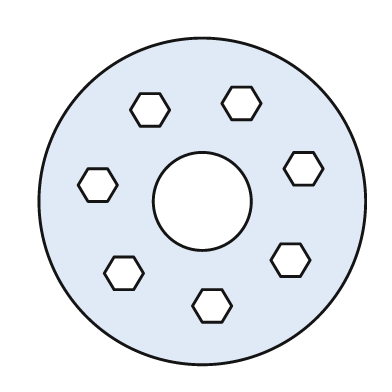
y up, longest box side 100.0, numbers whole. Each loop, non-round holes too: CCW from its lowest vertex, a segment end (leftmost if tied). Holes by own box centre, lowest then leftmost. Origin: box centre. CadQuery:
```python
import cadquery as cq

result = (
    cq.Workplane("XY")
    .moveTo(0.0, 0.0)
    .circle(50.0)
    .moveTo(0.0, -37.0)
    .lineTo(6.0, -37.0)
    .lineTo(9.0, -32.0)
    .lineTo(6.0, -27.0)
    .lineTo(0.0, -27.0)
    .lineTo(-3.0, -32.0)
    .close()
    .moveTo(-27.0, -27.0)
    .lineTo(-21.0, -27.0)
    .lineTo(-18.0, -22.0)
    .lineTo(-21.0, -17.0)
    .lineTo(-27.0, -17.0)
    .lineTo(-30.0, -22.0)
    .close()
    .moveTo(24.0, -23.0)
    .lineTo(30.0, -23.0)
    .lineTo(33.0, -18.0)
    .lineTo(30.0, -13.0)
    .lineTo(24.0, -13.0)
    .lineTo(21.0, -18.0)
    .close()
    .moveTo(0.0, 0.0)
    .circle(15.0)
    .moveTo(-35.0, 0.0)
    .lineTo(-29.0, 0.0)
    .lineTo(-26.0, 5.0)
    .lineTo(-29.0, 10.0)
    .lineTo(-35.0, 10.0)
    .lineTo(-38.0, 5.0)
    .close()
    .moveTo(28.0, 5.0)
    .lineTo(34.0, 5.0)
    .lineTo(37.0, 10.0)
    .lineTo(34.0, 15.0)
    .lineTo(28.0, 15.0)
    .lineTo(25.0, 10.0)
    .close()
    .moveTo(-19.0, 23.0)
    .lineTo(-13.0, 23.0)
    .lineTo(-10.0, 28.0)
    .lineTo(-13.0, 33.0)
    .lineTo(-19.0, 33.0)
    .lineTo(-22.0, 28.0)
    .close()
    .moveTo(9.0, 25.0)
    .lineTo(15.0, 25.0)
    .lineTo(18.0, 30.0)
    .lineTo(15.0, 35.0)
    .lineTo(9.0, 35.0)
    .lineTo(6.0, 30.0)
    .close()
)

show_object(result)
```